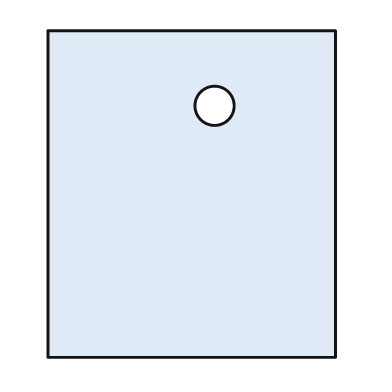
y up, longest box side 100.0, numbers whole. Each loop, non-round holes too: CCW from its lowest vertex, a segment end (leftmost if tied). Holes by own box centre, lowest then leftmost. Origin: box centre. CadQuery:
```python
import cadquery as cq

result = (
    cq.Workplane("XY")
    .moveTo(-44.0, -50.0)
    .lineTo(44.0, -50.0)
    .lineTo(44.0, 50.0)
    .lineTo(-44.0, 50.0)
    .close()
    .moveTo(7.0, 27.0)
    .circle(6.0)
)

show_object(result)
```